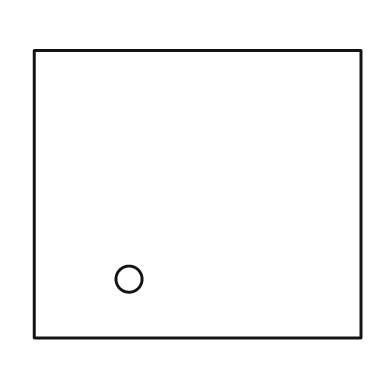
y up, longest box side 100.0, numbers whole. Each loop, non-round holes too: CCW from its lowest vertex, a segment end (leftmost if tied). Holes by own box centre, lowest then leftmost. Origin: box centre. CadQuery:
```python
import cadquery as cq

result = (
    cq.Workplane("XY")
    .moveTo(-50.0, -44.0)
    .lineTo(50.0, -44.0)
    .lineTo(50.0, 44.0)
    .lineTo(-50.0, 44.0)
    .close()
    .moveTo(-21.0, -26.0)
    .circle(4.0)
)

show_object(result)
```